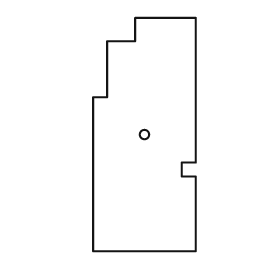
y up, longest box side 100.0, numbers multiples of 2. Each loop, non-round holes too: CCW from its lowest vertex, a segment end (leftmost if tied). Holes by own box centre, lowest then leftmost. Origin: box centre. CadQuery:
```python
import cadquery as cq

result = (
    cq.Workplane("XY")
    .moveTo(-22.0, -50.0)
    .lineTo(22.0, -50.0)
    .lineTo(22.0, -18.0)
    .lineTo(16.0, -18.0)
    .lineTo(16.0, -12.0)
    .lineTo(22.0, -12.0)
    .lineTo(22.0, 50.0)
    .lineTo(-4.0, 50.0)
    .lineTo(-4.0, 40.0)
    .lineTo(-16.0, 40.0)
    .lineTo(-16.0, 16.0)
    .lineTo(-22.0, 16.0)
    .close()
    .moveTo(0.0, 0.0)
    .circle(2.0)
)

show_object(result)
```